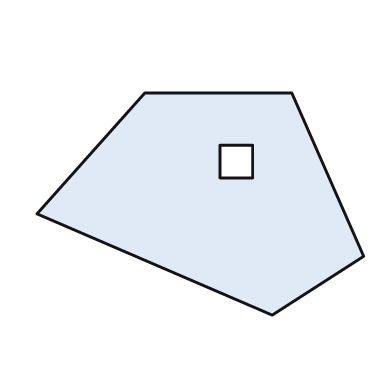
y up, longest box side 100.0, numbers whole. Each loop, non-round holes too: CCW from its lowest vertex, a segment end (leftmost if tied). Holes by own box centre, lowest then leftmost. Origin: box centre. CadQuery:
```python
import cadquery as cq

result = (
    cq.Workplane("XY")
    .moveTo(22.0, -34.0)
    .lineTo(50.0, -16.0)
    .lineTo(28.0, 34.0)
    .lineTo(-17.0, 34.0)
    .lineTo(-50.0, -3.0)
    .close()
    .moveTo(6.0, 8.0)
    .lineTo(16.0, 8.0)
    .lineTo(16.0, 18.0)
    .lineTo(6.0, 18.0)
    .close()
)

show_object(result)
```